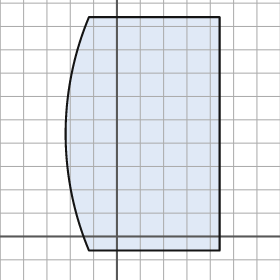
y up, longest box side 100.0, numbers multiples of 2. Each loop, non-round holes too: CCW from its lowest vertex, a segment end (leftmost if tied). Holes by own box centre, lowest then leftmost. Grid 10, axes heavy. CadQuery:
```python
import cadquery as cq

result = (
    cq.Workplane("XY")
    .moveTo(-12.0, -6.0)
    .lineTo(44.0, -6.0)
    .lineTo(44.0, 94.0)
    .lineTo(-12.0, 94.0)
    .threePointArc((-22.0, 44.0), (-12.0, -6.0))
    .close()
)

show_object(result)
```